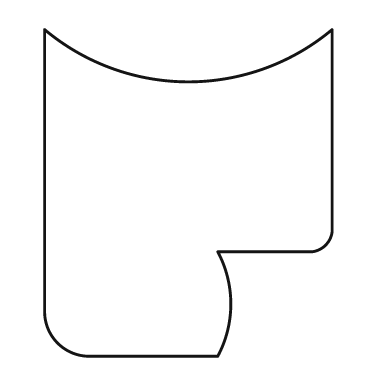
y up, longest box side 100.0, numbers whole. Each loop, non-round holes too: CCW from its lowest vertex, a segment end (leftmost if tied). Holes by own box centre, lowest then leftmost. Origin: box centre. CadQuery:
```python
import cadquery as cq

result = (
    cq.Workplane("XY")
    .moveTo(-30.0, -50.0)
    .lineTo(9.0, -50.0)
    .threePointArc((13.0, -34.0), (9.0, -18.0))
    .lineTo(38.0, -18.0)
    .threePointArc((42.0, -16.0), (44.0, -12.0))
    .lineTo(44.0, 50.0)
    .threePointArc((0.0, 34.0), (-44.0, 50.0))
    .lineTo(-44.0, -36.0)
    .threePointArc((-40.0, -46.0), (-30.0, -50.0))
    .close()
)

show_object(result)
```